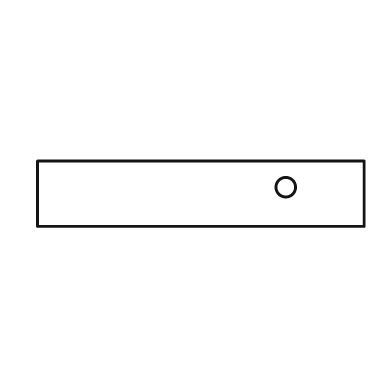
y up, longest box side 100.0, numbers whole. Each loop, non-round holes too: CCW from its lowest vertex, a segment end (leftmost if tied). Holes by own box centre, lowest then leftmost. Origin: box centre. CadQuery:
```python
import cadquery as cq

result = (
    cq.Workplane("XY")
    .moveTo(-50.0, -10.0)
    .lineTo(50.0, -10.0)
    .lineTo(50.0, 10.0)
    .lineTo(-50.0, 10.0)
    .close()
    .moveTo(26.0, 2.0)
    .circle(3.0)
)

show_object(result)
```